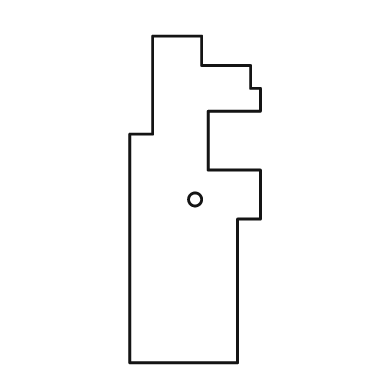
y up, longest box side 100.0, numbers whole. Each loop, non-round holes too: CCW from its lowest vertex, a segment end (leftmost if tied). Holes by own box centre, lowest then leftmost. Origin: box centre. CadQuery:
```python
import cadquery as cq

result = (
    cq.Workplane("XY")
    .moveTo(-20.0, -50.0)
    .lineTo(13.0, -50.0)
    .lineTo(13.0, -6.0)
    .lineTo(20.0, -6.0)
    .lineTo(20.0, 9.0)
    .lineTo(4.0, 9.0)
    .lineTo(4.0, 27.0)
    .lineTo(20.0, 27.0)
    .lineTo(20.0, 34.0)
    .lineTo(17.0, 34.0)
    .lineTo(17.0, 41.0)
    .lineTo(2.0, 41.0)
    .lineTo(2.0, 50.0)
    .lineTo(-13.0, 50.0)
    .lineTo(-13.0, 20.0)
    .lineTo(-20.0, 20.0)
    .close()
    .moveTo(0.0, 0.0)
    .circle(2.0)
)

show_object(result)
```